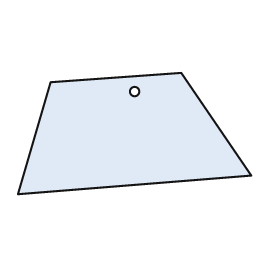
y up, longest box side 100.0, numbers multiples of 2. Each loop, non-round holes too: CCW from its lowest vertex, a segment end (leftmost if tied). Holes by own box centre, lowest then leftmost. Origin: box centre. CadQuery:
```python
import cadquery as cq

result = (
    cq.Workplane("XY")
    .moveTo(-50.0, -26.0)
    .lineTo(50.0, -18.0)
    .lineTo(20.0, 26.0)
    .lineTo(-36.0, 22.0)
    .close()
    .moveTo(0.0, 18.0)
    .circle(2.0)
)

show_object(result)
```